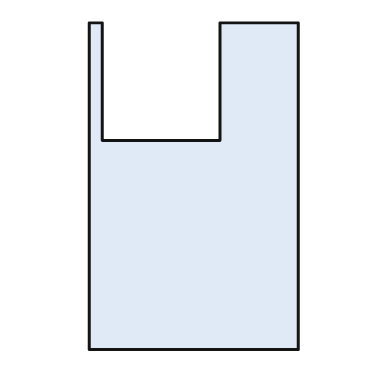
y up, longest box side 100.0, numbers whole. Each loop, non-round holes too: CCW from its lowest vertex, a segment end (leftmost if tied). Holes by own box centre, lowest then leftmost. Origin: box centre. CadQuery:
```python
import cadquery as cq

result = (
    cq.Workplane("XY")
    .moveTo(-32.0, -50.0)
    .lineTo(32.0, -50.0)
    .lineTo(32.0, 50.0)
    .lineTo(8.0, 50.0)
    .lineTo(8.0, 14.0)
    .lineTo(-28.0, 14.0)
    .lineTo(-28.0, 50.0)
    .lineTo(-32.0, 50.0)
    .close()
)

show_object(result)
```